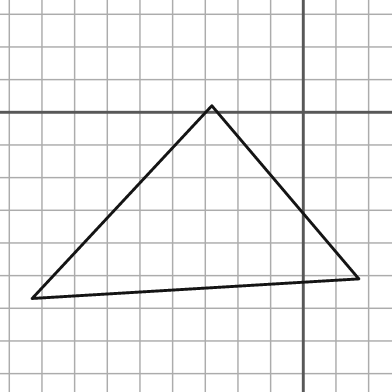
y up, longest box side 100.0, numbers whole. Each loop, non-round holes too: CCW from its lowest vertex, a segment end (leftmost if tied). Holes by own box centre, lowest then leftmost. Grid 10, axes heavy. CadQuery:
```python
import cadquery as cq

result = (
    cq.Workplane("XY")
    .moveTo(-83.0, -57.0)
    .lineTo(17.0, -51.0)
    .lineTo(-28.0, 2.0)
    .close()
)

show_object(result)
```